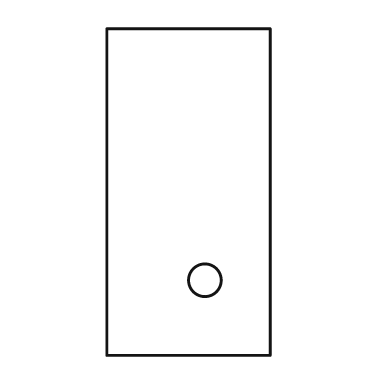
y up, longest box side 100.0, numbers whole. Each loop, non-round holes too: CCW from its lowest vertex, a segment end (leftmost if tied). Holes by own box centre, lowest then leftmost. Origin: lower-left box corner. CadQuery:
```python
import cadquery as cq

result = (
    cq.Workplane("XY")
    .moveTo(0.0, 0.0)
    .lineTo(50.0, 0.0)
    .lineTo(50.0, 100.0)
    .lineTo(0.0, 100.0)
    .close()
    .moveTo(30.0, 23.0)
    .circle(5.0)
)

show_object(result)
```